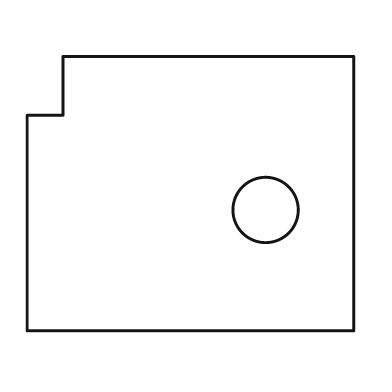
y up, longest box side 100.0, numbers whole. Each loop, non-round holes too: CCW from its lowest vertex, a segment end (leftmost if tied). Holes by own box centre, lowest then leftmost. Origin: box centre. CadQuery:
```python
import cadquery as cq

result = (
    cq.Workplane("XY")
    .moveTo(-50.0, -42.0)
    .lineTo(50.0, -42.0)
    .lineTo(50.0, 42.0)
    .lineTo(-39.0, 42.0)
    .lineTo(-39.0, 24.0)
    .lineTo(-50.0, 24.0)
    .close()
    .moveTo(23.0, -5.0)
    .circle(10.0)
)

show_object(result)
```